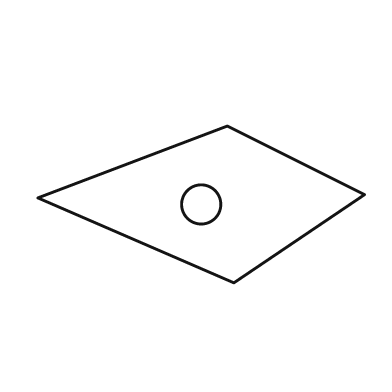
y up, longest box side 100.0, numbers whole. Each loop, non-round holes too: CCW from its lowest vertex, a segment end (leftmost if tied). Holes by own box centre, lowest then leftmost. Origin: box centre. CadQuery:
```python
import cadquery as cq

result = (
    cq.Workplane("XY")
    .moveTo(10.0, -24.0)
    .lineTo(50.0, 3.0)
    .lineTo(8.0, 24.0)
    .lineTo(-50.0, 2.0)
    .close()
    .moveTo(0.0, 0.0)
    .circle(6.0)
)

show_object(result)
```